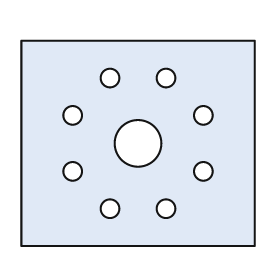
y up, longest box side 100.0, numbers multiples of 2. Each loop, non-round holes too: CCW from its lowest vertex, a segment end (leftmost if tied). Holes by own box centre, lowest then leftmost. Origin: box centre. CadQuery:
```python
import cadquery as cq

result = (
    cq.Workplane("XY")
    .moveTo(-50.0, -44.0)
    .lineTo(50.0, -44.0)
    .lineTo(50.0, 44.0)
    .lineTo(-50.0, 44.0)
    .close()
    .moveTo(-12.0, -28.0)
    .circle(4.0)
    .moveTo(12.0, -28.0)
    .circle(4.0)
    .moveTo(-28.0, -12.0)
    .circle(4.0)
    .moveTo(28.0, -12.0)
    .circle(4.0)
    .moveTo(0.0, 0.0)
    .circle(10.0)
    .moveTo(-28.0, 12.0)
    .circle(4.0)
    .moveTo(28.0, 12.0)
    .circle(4.0)
    .moveTo(-12.0, 28.0)
    .circle(4.0)
    .moveTo(12.0, 28.0)
    .circle(4.0)
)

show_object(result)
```